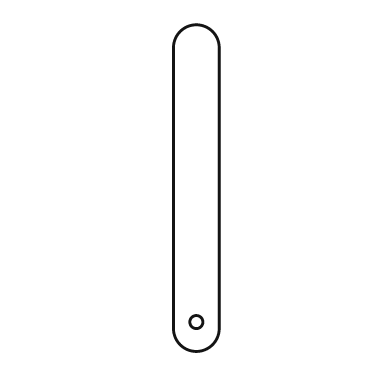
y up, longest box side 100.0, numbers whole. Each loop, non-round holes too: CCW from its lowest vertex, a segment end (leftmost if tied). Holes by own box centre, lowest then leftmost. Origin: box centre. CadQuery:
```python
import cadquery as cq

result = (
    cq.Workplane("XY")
    .moveTo(-7.0, -43.0)
    .threePointArc((0.0, -50.0), (7.0, -43.0))
    .lineTo(7.0, 43.0)
    .threePointArc((0.0, 50.0), (-7.0, 43.0))
    .close()
    .moveTo(0.0, -41.0)
    .circle(2.0)
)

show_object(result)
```